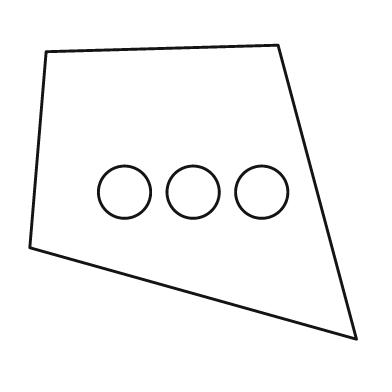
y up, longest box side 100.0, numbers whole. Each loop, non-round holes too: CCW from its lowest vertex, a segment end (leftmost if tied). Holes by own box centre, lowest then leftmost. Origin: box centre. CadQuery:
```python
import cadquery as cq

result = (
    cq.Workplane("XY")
    .moveTo(50.0, -45.0)
    .lineTo(26.0, 45.0)
    .lineTo(-45.0, 43.0)
    .lineTo(-50.0, -17.0)
    .close()
    .moveTo(-21.0, 0.0)
    .circle(8.0)
    .moveTo(0.0, 0.0)
    .circle(8.0)
    .moveTo(21.0, 0.0)
    .circle(8.0)
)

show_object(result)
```